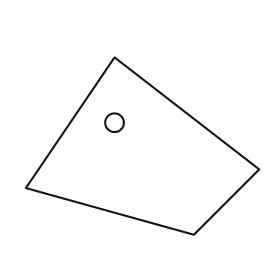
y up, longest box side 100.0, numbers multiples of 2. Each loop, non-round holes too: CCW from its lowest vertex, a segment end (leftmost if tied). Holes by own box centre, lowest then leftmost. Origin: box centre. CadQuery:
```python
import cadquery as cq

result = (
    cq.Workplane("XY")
    .moveTo(22.0, -38.0)
    .lineTo(50.0, -10.0)
    .lineTo(-12.0, 38.0)
    .lineTo(-50.0, -18.0)
    .close()
    .moveTo(-12.0, 10.0)
    .circle(4.0)
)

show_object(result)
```